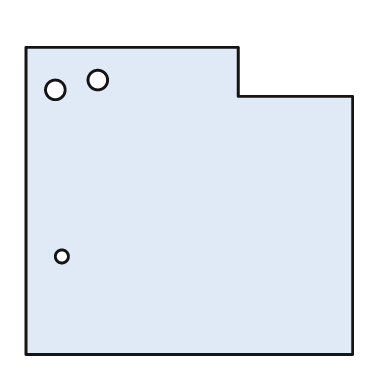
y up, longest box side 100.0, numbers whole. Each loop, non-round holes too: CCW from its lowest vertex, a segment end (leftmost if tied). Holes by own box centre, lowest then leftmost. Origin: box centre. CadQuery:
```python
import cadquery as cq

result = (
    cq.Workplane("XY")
    .moveTo(-50.0, -47.0)
    .lineTo(50.0, -47.0)
    .lineTo(50.0, 32.0)
    .lineTo(15.0, 32.0)
    .lineTo(15.0, 47.0)
    .lineTo(-50.0, 47.0)
    .close()
    .moveTo(-39.0, -17.0)
    .circle(2.0)
    .moveTo(-41.0, 34.0)
    .circle(3.0)
    .moveTo(-28.0, 37.0)
    .circle(3.0)
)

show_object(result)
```